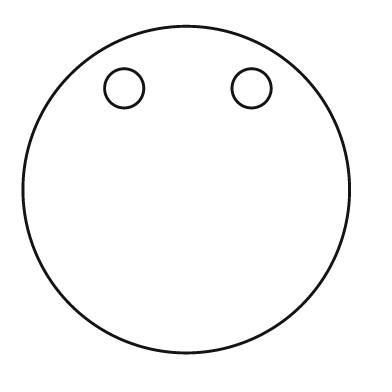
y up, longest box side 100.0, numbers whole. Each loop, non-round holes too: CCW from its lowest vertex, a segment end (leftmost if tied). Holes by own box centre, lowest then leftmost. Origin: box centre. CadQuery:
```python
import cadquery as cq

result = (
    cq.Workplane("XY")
    .moveTo(0.0, 0.0)
    .circle(50.0)
    .moveTo(-19.0, 31.0)
    .circle(6.0)
    .moveTo(20.0, 31.0)
    .circle(6.0)
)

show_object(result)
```